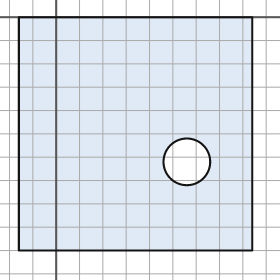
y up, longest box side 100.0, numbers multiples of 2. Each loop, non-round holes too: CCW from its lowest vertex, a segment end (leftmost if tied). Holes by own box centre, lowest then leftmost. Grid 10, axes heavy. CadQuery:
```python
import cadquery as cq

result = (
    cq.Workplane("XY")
    .moveTo(-16.0, -100.0)
    .lineTo(84.0, -100.0)
    .lineTo(84.0, 0.0)
    .lineTo(-16.0, 0.0)
    .close()
    .moveTo(56.0, -62.0)
    .circle(10.0)
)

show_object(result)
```